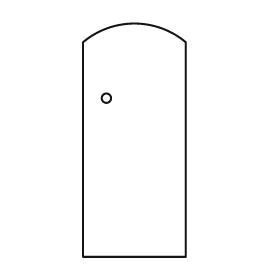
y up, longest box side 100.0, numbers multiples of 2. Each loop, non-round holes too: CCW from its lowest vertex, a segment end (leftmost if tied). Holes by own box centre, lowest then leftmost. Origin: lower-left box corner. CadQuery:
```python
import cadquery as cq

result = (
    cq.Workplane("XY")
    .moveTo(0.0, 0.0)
    .lineTo(44.0, 0.0)
    .lineTo(44.0, 92.0)
    .threePointArc((22.0, 100.0), (0.0, 92.0))
    .close()
    .moveTo(10.0, 68.0)
    .circle(2.0)
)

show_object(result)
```